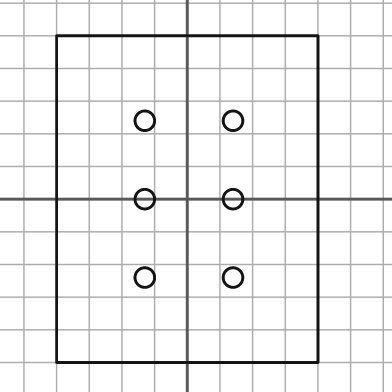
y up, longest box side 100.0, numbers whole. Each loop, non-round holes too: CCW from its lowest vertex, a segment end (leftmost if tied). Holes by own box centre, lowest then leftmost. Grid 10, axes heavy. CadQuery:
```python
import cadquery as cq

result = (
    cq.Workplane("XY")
    .moveTo(-40.0, -50.0)
    .lineTo(40.0, -50.0)
    .lineTo(40.0, 50.0)
    .lineTo(-40.0, 50.0)
    .close()
    .moveTo(-13.0, -24.0)
    .circle(3.0)
    .moveTo(14.0, -24.0)
    .circle(3.0)
    .moveTo(-13.0, 0.0)
    .circle(3.0)
    .moveTo(14.0, 0.0)
    .circle(3.0)
    .moveTo(-13.0, 24.0)
    .circle(3.0)
    .moveTo(14.0, 24.0)
    .circle(3.0)
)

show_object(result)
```